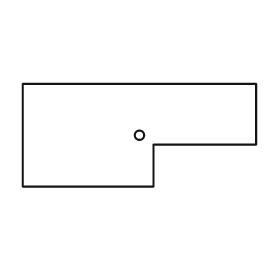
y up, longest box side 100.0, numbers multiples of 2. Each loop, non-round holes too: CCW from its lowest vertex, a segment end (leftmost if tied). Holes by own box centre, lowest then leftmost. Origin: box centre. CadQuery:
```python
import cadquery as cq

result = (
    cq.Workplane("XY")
    .moveTo(-50.0, -22.0)
    .lineTo(6.0, -22.0)
    .lineTo(6.0, -4.0)
    .lineTo(50.0, -4.0)
    .lineTo(50.0, 22.0)
    .lineTo(-50.0, 22.0)
    .close()
    .moveTo(0.0, 0.0)
    .circle(2.0)
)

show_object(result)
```